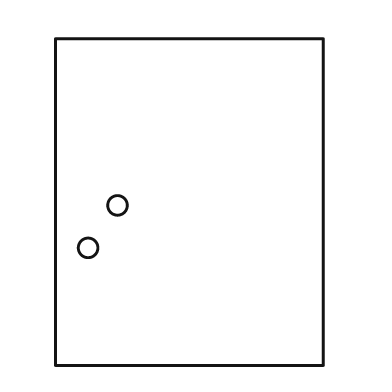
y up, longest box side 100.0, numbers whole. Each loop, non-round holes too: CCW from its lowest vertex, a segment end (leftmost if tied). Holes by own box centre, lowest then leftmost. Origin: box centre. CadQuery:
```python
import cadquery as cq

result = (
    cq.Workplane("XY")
    .moveTo(-41.0, -50.0)
    .lineTo(41.0, -50.0)
    .lineTo(41.0, 50.0)
    .lineTo(-41.0, 50.0)
    .close()
    .moveTo(-31.0, -14.0)
    .circle(3.0)
    .moveTo(-22.0, -1.0)
    .circle(3.0)
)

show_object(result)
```